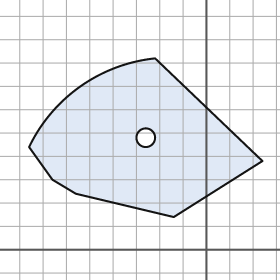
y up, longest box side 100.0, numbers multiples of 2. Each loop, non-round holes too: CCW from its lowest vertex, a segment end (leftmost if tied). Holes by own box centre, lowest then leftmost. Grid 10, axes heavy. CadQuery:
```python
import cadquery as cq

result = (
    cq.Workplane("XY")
    .moveTo(-14.0, 14.0)
    .lineTo(24.0, 38.0)
    .lineTo(-22.0, 82.0)
    .threePointArc((-54.0, 70.0), (-76.0, 44.0))
    .lineTo(-66.0, 30.0)
    .lineTo(-56.0, 24.0)
    .close()
    .moveTo(-26.0, 48.0)
    .circle(4.0)
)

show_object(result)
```